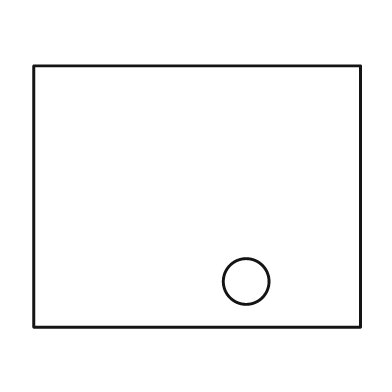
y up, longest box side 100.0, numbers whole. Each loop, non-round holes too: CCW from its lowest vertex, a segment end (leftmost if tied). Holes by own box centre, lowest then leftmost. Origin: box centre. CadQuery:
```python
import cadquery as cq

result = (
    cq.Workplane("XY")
    .moveTo(-50.0, -40.0)
    .lineTo(50.0, -40.0)
    .lineTo(50.0, 40.0)
    .lineTo(-50.0, 40.0)
    .close()
    .moveTo(15.0, -26.0)
    .circle(7.0)
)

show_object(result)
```